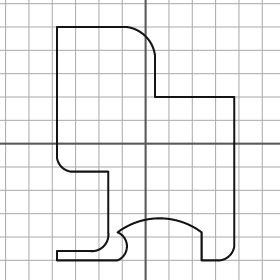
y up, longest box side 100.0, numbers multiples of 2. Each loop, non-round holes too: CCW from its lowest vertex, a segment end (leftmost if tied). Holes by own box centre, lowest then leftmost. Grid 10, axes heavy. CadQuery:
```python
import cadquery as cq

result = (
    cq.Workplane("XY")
    .moveTo(-38.0, -50.0)
    .lineTo(-12.0, -50.0)
    .threePointArc((-8.0, -44.0), (-12.0, -38.0))
    .threePointArc((6.0, -32.0), (24.0, -38.0))
    .lineTo(24.0, -50.0)
    .lineTo(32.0, -50.0)
    .threePointArc((36.0, -48.0), (38.0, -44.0))
    .lineTo(38.0, 20.0)
    .lineTo(4.0, 20.0)
    .lineTo(4.0, 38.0)
    .threePointArc((0.0, 46.0), (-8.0, 50.0))
    .lineTo(-38.0, 50.0)
    .lineTo(-38.0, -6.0)
    .threePointArc((-36.0, -10.0), (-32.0, -12.0))
    .lineTo(-16.0, -12.0)
    .lineTo(-16.0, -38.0)
    .threePointArc((-18.0, -44.0), (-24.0, -46.0))
    .lineTo(-38.0, -46.0)
    .close()
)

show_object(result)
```